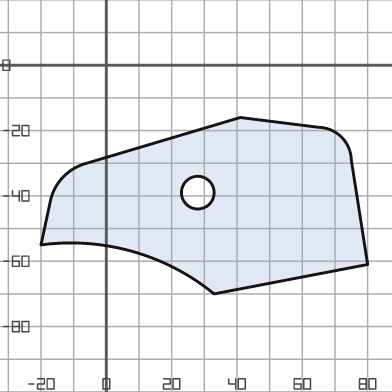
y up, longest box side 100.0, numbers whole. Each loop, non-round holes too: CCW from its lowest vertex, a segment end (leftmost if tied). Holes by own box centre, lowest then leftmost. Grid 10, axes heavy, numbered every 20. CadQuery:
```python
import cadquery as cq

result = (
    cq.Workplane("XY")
    .moveTo(33.0, -70.0)
    .lineTo(80.0, -61.0)
    .lineTo(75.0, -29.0)
    .threePointArc((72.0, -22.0), (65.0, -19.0))
    .lineTo(41.0, -16.0)
    .lineTo(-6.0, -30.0)
    .threePointArc((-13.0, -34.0), (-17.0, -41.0))
    .lineTo(-20.0, -55.0)
    .threePointArc((8.0, -57.0), (33.0, -70.0))
    .close()
    .moveTo(28.0, -39.0)
    .circle(5.0)
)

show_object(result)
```